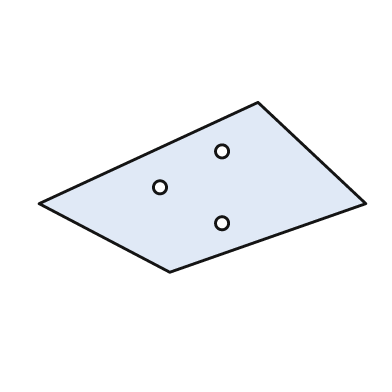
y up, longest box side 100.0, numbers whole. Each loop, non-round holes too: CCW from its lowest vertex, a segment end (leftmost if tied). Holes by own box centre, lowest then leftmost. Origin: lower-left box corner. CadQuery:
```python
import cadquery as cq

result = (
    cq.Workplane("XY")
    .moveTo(40.0, 0.0)
    .lineTo(100.0, 21.0)
    .lineTo(67.0, 52.0)
    .lineTo(0.0, 21.0)
    .close()
    .moveTo(56.0, 15.0)
    .circle(2.0)
    .moveTo(37.0, 26.0)
    .circle(2.0)
    .moveTo(56.0, 37.0)
    .circle(2.0)
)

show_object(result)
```